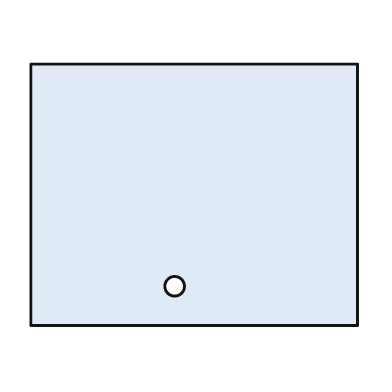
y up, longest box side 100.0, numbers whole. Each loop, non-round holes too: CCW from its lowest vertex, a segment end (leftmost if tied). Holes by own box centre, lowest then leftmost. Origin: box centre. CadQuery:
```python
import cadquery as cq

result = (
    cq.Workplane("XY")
    .moveTo(-50.0, -40.0)
    .lineTo(50.0, -40.0)
    .lineTo(50.0, 40.0)
    .lineTo(-50.0, 40.0)
    .close()
    .moveTo(-6.0, -28.0)
    .circle(3.0)
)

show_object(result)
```